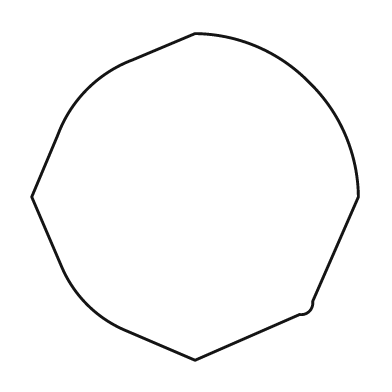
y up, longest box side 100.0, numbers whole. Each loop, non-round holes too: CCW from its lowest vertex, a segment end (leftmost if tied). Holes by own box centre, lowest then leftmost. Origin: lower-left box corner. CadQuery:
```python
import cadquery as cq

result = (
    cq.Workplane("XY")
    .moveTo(50.0, 0.0)
    .lineTo(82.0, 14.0)
    .threePointArc((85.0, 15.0), (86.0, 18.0))
    .lineTo(100.0, 50.0)
    .threePointArc((96.0, 69.0), (85.0, 85.0))
    .threePointArc((69.0, 96.0), (50.0, 100.0))
    .lineTo(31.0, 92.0)
    .threePointArc((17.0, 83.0), (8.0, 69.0))
    .lineTo(0.0, 50.0)
    .lineTo(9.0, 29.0)
    .threePointArc((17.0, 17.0), (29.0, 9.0))
    .close()
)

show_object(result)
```